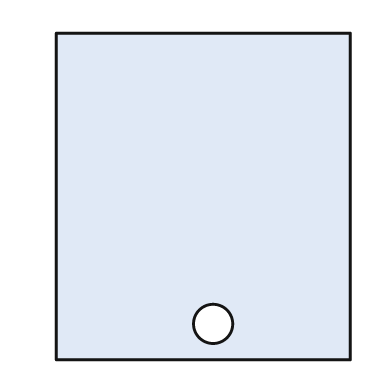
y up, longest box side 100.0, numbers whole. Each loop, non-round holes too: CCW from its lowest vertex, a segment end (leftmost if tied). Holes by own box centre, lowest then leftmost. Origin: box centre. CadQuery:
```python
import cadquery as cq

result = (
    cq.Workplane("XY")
    .moveTo(-45.0, -50.0)
    .lineTo(45.0, -50.0)
    .lineTo(45.0, 50.0)
    .lineTo(-45.0, 50.0)
    .close()
    .moveTo(3.0, -39.0)
    .circle(6.0)
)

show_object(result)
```